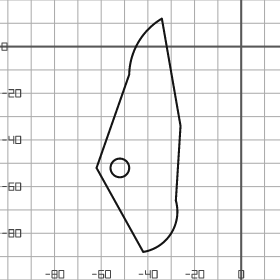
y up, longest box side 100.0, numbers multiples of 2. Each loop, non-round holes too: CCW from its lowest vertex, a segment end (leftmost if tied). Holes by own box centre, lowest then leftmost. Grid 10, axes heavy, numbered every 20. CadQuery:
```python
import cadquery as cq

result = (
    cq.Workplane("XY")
    .moveTo(-42.0, -88.0)
    .threePointArc((-30.0, -80.0), (-28.0, -66.0))
    .lineTo(-26.0, -34.0)
    .lineTo(-34.0, 12.0)
    .threePointArc((-44.0, 2.0), (-48.0, -12.0))
    .lineTo(-62.0, -52.0)
    .close()
    .moveTo(-52.0, -52.0)
    .circle(4.0)
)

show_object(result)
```